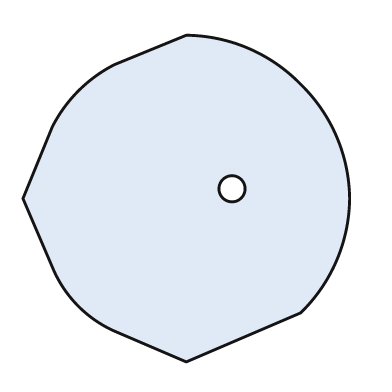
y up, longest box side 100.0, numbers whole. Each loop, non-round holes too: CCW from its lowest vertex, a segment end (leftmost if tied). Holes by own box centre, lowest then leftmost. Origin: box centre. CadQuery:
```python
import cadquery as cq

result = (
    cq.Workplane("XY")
    .moveTo(0.0, -50.0)
    .lineTo(35.0, -35.0)
    .threePointArc((46.0, -19.0), (50.0, 0.0))
    .threePointArc((46.0, 19.0), (35.0, 35.0))
    .threePointArc((19.0, 46.0), (0.0, 50.0))
    .lineTo(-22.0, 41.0)
    .threePointArc((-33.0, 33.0), (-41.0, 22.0))
    .lineTo(-50.0, 0.0)
    .lineTo(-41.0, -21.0)
    .threePointArc((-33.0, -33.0), (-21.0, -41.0))
    .close()
    .moveTo(14.0, 3.0)
    .circle(4.0)
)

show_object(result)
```